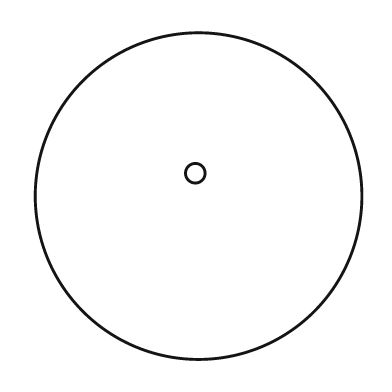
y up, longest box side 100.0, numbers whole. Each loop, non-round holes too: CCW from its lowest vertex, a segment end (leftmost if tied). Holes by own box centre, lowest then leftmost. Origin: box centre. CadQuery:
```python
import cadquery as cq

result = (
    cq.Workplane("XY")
    .moveTo(0.0, 0.0)
    .circle(50.0)
    .moveTo(-1.0, 7.0)
    .circle(3.0)
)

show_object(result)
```